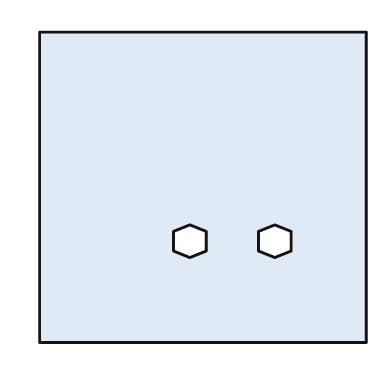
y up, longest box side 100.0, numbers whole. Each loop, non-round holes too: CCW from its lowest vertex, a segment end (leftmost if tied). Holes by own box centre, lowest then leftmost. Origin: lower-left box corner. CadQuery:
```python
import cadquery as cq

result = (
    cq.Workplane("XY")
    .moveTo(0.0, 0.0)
    .lineTo(100.0, 0.0)
    .lineTo(100.0, 95.0)
    .lineTo(0.0, 95.0)
    .close()
    .moveTo(46.0, 26.0)
    .lineTo(51.0, 28.0)
    .lineTo(51.0, 34.0)
    .lineTo(46.0, 36.0)
    .lineTo(41.0, 34.0)
    .lineTo(41.0, 28.0)
    .close()
    .moveTo(72.0, 26.0)
    .lineTo(77.0, 28.0)
    .lineTo(77.0, 34.0)
    .lineTo(72.0, 36.0)
    .lineTo(67.0, 34.0)
    .lineTo(67.0, 28.0)
    .close()
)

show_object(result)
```